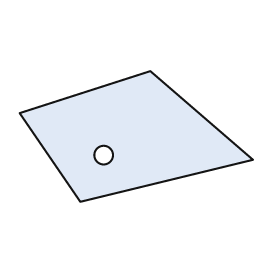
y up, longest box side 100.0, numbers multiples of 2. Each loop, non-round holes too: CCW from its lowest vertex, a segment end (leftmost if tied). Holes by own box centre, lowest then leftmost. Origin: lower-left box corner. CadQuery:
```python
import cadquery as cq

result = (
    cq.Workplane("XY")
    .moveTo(26.0, 0.0)
    .lineTo(100.0, 18.0)
    .lineTo(56.0, 56.0)
    .lineTo(0.0, 38.0)
    .close()
    .moveTo(36.0, 20.0)
    .circle(4.0)
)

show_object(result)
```